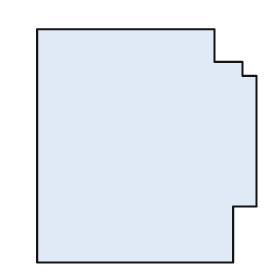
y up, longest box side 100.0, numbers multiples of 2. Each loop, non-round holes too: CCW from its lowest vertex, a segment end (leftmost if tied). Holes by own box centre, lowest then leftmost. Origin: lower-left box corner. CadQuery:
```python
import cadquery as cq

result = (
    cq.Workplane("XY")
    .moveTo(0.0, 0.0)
    .lineTo(84.0, 0.0)
    .lineTo(84.0, 24.0)
    .lineTo(94.0, 24.0)
    .lineTo(94.0, 80.0)
    .lineTo(88.0, 80.0)
    .lineTo(88.0, 86.0)
    .lineTo(76.0, 86.0)
    .lineTo(76.0, 100.0)
    .lineTo(0.0, 100.0)
    .close()
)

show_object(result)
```